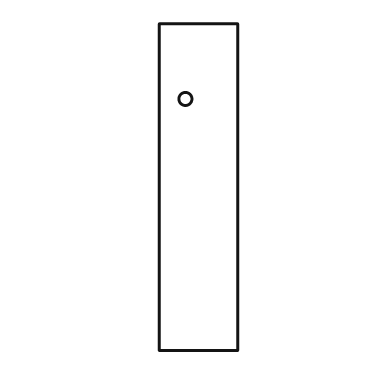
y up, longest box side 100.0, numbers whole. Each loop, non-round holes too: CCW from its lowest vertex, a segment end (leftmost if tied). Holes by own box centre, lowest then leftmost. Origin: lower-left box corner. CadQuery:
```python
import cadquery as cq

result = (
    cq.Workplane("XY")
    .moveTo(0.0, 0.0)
    .lineTo(24.0, 0.0)
    .lineTo(24.0, 100.0)
    .lineTo(0.0, 100.0)
    .close()
    .moveTo(8.0, 77.0)
    .circle(2.0)
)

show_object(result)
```